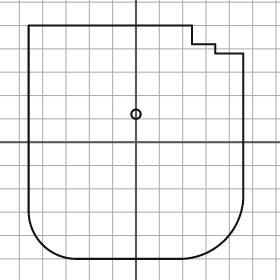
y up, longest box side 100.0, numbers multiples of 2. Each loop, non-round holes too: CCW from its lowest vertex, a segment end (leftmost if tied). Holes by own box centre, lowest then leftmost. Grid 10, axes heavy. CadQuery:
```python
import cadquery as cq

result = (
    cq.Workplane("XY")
    .moveTo(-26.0, -50.0)
    .lineTo(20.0, -50.0)
    .threePointArc((38.0, -42.0), (46.0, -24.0))
    .lineTo(46.0, 38.0)
    .lineTo(34.0, 38.0)
    .lineTo(34.0, 42.0)
    .lineTo(24.0, 42.0)
    .lineTo(24.0, 50.0)
    .lineTo(-46.0, 50.0)
    .lineTo(-46.0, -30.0)
    .threePointArc((-40.0, -44.0), (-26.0, -50.0))
    .close()
    .moveTo(0.0, 12.0)
    .circle(2.0)
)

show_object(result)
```